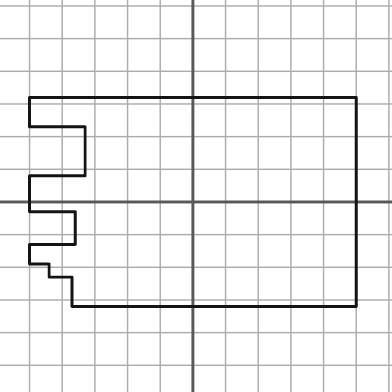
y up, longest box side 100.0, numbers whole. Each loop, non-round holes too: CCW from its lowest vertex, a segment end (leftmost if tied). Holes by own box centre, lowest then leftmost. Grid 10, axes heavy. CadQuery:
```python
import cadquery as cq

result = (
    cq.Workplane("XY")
    .moveTo(-37.0, -32.0)
    .lineTo(50.0, -32.0)
    .lineTo(50.0, 32.0)
    .lineTo(-50.0, 32.0)
    .lineTo(-50.0, 23.0)
    .lineTo(-33.0, 23.0)
    .lineTo(-33.0, 8.0)
    .lineTo(-50.0, 8.0)
    .lineTo(-50.0, -3.0)
    .lineTo(-36.0, -3.0)
    .lineTo(-36.0, -13.0)
    .lineTo(-50.0, -13.0)
    .lineTo(-50.0, -19.0)
    .lineTo(-44.0, -19.0)
    .lineTo(-44.0, -23.0)
    .lineTo(-37.0, -23.0)
    .close()
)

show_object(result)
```